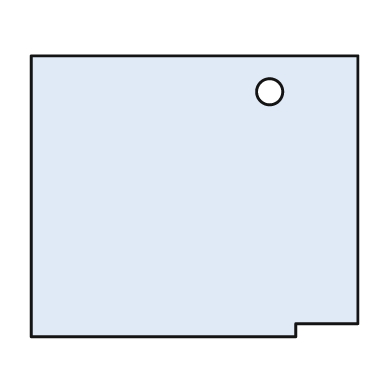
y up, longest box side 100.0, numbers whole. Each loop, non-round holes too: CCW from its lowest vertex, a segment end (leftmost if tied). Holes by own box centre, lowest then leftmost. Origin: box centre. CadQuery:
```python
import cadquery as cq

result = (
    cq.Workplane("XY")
    .moveTo(-50.0, -43.0)
    .lineTo(31.0, -43.0)
    .lineTo(31.0, -39.0)
    .lineTo(50.0, -39.0)
    .lineTo(50.0, 43.0)
    .lineTo(-50.0, 43.0)
    .close()
    .moveTo(23.0, 32.0)
    .circle(4.0)
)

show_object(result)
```